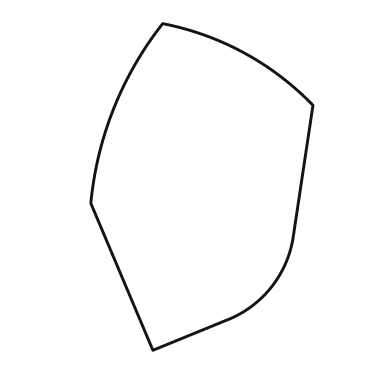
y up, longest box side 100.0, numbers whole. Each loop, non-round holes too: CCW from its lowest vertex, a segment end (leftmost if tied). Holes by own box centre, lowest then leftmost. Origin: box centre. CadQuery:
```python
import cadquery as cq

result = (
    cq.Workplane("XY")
    .moveTo(-15.0, -50.0)
    .lineTo(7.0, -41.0)
    .threePointArc((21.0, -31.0), (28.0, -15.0))
    .lineTo(34.0, 25.0)
    .threePointArc((13.0, 41.0), (-12.0, 50.0))
    .threePointArc((-27.0, 24.0), (-34.0, -5.0))
    .close()
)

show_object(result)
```